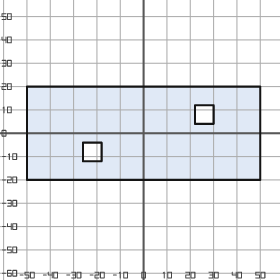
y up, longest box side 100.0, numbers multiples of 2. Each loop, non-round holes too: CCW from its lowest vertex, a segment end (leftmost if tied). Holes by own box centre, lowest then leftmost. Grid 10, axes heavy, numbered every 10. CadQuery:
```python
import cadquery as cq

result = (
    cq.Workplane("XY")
    .moveTo(-50.0, -20.0)
    .lineTo(50.0, -20.0)
    .lineTo(50.0, 20.0)
    .lineTo(-50.0, 20.0)
    .close()
    .moveTo(-26.0, -12.0)
    .lineTo(-18.0, -12.0)
    .lineTo(-18.0, -4.0)
    .lineTo(-26.0, -4.0)
    .close()
    .moveTo(22.0, 4.0)
    .lineTo(30.0, 4.0)
    .lineTo(30.0, 12.0)
    .lineTo(22.0, 12.0)
    .close()
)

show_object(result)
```